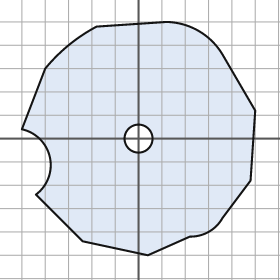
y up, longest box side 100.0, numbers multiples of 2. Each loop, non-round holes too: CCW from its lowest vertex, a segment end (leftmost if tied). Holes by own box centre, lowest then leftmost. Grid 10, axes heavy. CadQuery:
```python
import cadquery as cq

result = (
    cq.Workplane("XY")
    .moveTo(4.0, -50.0)
    .lineTo(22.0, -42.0)
    .threePointArc((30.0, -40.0), (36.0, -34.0))
    .lineTo(48.0, -18.0)
    .lineTo(50.0, 12.0)
    .lineTo(36.0, 36.0)
    .threePointArc((26.0, 46.0), (12.0, 50.0))
    .lineTo(-18.0, 48.0)
    .threePointArc((-30.0, 40.0), (-40.0, 30.0))
    .lineTo(-50.0, 4.0)
    .threePointArc((-38.0, -8.0), (-44.0, -24.0))
    .lineTo(-24.0, -44.0)
    .close()
    .moveTo(0.0, 0.0)
    .circle(6.0)
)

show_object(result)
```